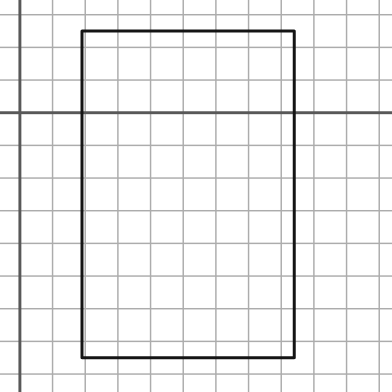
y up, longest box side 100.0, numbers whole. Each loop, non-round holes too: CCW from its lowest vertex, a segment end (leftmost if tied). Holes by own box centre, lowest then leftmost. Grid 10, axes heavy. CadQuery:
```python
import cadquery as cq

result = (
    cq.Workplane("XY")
    .moveTo(19.0, -75.0)
    .lineTo(84.0, -75.0)
    .lineTo(84.0, 25.0)
    .lineTo(19.0, 25.0)
    .close()
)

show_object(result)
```